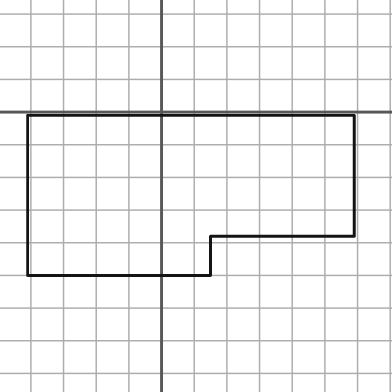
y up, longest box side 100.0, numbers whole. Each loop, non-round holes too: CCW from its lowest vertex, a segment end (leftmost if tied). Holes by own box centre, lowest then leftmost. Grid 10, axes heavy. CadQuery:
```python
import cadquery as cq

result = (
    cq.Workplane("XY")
    .moveTo(-41.0, -50.0)
    .lineTo(15.0, -50.0)
    .lineTo(15.0, -38.0)
    .lineTo(59.0, -38.0)
    .lineTo(59.0, -1.0)
    .lineTo(-41.0, -1.0)
    .close()
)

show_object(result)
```